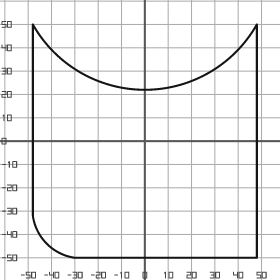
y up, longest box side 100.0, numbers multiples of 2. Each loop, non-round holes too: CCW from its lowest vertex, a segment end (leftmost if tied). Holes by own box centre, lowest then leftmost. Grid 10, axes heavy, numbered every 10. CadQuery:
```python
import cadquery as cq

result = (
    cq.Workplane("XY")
    .moveTo(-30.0, -50.0)
    .lineTo(48.0, -50.0)
    .lineTo(48.0, 50.0)
    .threePointArc((0.0, 22.0), (-48.0, 50.0))
    .lineTo(-48.0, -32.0)
    .threePointArc((-42.0, -44.0), (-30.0, -50.0))
    .close()
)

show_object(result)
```